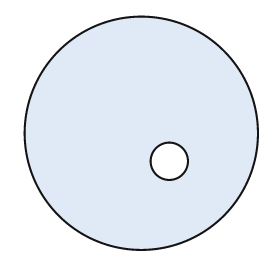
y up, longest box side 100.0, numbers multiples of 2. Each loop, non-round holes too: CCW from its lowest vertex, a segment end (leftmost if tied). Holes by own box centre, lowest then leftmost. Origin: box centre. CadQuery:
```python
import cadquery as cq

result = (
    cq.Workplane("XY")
    .moveTo(0.0, 0.0)
    .circle(50.0)
    .moveTo(12.0, -12.0)
    .circle(8.0)
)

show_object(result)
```